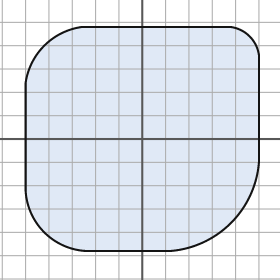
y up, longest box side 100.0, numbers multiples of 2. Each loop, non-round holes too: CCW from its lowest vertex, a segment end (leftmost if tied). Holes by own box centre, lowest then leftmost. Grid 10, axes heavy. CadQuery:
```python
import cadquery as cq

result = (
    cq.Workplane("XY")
    .moveTo(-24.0, -48.0)
    .lineTo(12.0, -48.0)
    .threePointArc((38.0, -36.0), (50.0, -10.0))
    .lineTo(50.0, 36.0)
    .threePointArc((46.0, 44.0), (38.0, 48.0))
    .lineTo(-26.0, 48.0)
    .threePointArc((-42.0, 40.0), (-50.0, 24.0))
    .lineTo(-50.0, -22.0)
    .threePointArc((-42.0, -40.0), (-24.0, -48.0))
    .close()
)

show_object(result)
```